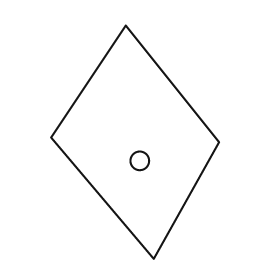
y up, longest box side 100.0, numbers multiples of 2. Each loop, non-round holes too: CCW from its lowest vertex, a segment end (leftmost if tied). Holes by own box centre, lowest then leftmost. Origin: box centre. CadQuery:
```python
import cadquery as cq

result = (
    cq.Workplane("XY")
    .moveTo(8.0, -50.0)
    .lineTo(36.0, 0.0)
    .lineTo(-4.0, 50.0)
    .lineTo(-36.0, 2.0)
    .close()
    .moveTo(2.0, -8.0)
    .circle(4.0)
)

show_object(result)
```